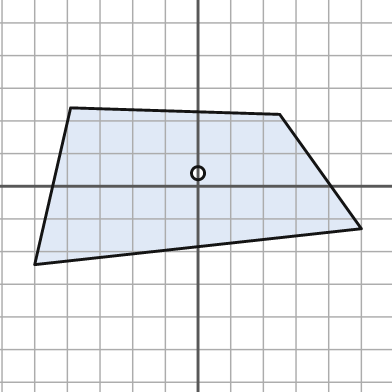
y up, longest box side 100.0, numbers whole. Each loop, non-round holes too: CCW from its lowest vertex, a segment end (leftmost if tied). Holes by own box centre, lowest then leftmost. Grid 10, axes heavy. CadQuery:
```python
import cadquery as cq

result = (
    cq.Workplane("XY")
    .moveTo(-50.0, -24.0)
    .lineTo(50.0, -13.0)
    .lineTo(25.0, 22.0)
    .lineTo(-39.0, 24.0)
    .close()
    .moveTo(0.0, 4.0)
    .circle(2.0)
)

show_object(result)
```